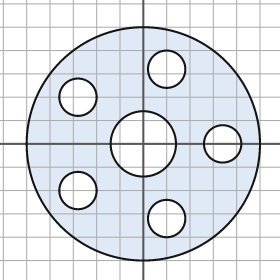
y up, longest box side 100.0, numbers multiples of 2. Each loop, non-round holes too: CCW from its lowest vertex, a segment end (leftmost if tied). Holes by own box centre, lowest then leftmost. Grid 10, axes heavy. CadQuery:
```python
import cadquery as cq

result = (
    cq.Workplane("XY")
    .moveTo(0.0, 0.0)
    .circle(50.0)
    .moveTo(10.0, -32.0)
    .circle(8.0)
    .moveTo(-28.0, -20.0)
    .circle(8.0)
    .moveTo(0.0, 0.0)
    .circle(14.0)
    .moveTo(34.0, 0.0)
    .circle(8.0)
    .moveTo(-28.0, 20.0)
    .circle(8.0)
    .moveTo(10.0, 32.0)
    .circle(8.0)
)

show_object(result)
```